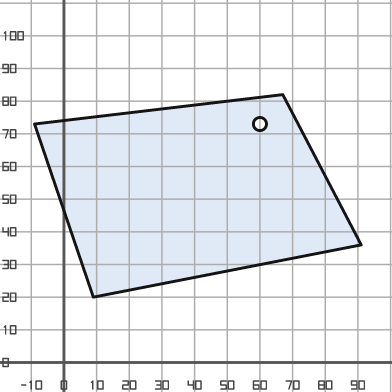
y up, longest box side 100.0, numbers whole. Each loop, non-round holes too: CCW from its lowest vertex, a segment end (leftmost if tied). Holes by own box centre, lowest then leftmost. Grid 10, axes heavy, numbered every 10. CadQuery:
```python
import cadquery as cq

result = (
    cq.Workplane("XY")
    .moveTo(9.0, 20.0)
    .lineTo(91.0, 36.0)
    .lineTo(67.0, 82.0)
    .lineTo(-9.0, 73.0)
    .close()
    .moveTo(60.0, 73.0)
    .circle(2.0)
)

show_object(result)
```